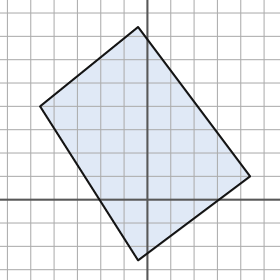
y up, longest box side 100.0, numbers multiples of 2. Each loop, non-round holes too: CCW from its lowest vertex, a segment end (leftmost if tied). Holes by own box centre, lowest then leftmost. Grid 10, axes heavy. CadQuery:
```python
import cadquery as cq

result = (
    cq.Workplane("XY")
    .moveTo(-4.0, -26.0)
    .lineTo(44.0, 10.0)
    .lineTo(-4.0, 74.0)
    .lineTo(-46.0, 40.0)
    .close()
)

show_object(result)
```